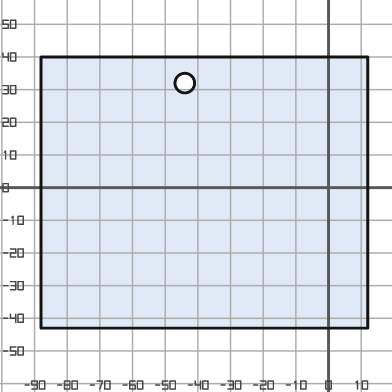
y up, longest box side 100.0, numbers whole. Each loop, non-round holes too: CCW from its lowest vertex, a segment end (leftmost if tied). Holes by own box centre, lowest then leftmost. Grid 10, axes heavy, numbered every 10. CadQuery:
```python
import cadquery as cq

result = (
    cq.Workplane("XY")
    .moveTo(-88.0, -43.0)
    .lineTo(12.0, -43.0)
    .lineTo(12.0, 40.0)
    .lineTo(-88.0, 40.0)
    .close()
    .moveTo(-44.0, 32.0)
    .circle(3.0)
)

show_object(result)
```